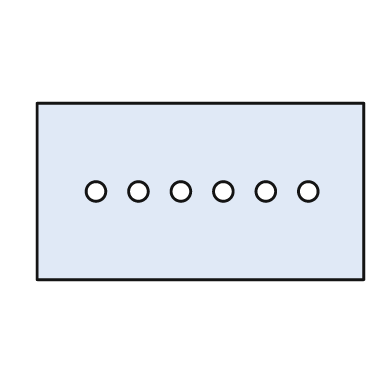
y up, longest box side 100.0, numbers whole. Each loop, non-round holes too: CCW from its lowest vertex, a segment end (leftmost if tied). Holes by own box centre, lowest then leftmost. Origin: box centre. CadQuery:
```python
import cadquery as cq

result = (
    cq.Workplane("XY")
    .moveTo(-50.0, -27.0)
    .lineTo(50.0, -27.0)
    .lineTo(50.0, 27.0)
    .lineTo(-50.0, 27.0)
    .close()
    .moveTo(-32.0, 0.0)
    .circle(3.0)
    .moveTo(-19.0, 0.0)
    .circle(3.0)
    .moveTo(-6.0, 0.0)
    .circle(3.0)
    .moveTo(7.0, 0.0)
    .circle(3.0)
    .moveTo(20.0, 0.0)
    .circle(3.0)
    .moveTo(33.0, 0.0)
    .circle(3.0)
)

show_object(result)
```